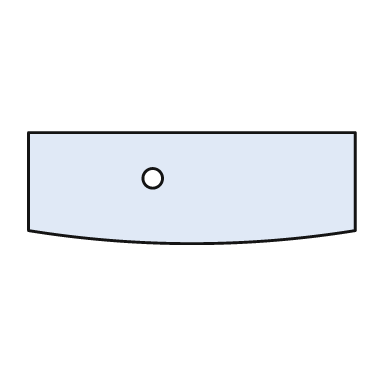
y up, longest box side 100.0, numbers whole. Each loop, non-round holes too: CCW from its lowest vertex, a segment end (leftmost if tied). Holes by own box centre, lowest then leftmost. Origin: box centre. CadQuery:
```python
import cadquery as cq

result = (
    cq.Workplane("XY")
    .moveTo(-50.0, -13.0)
    .threePointArc((0.0, -17.0), (50.0, -13.0))
    .lineTo(50.0, 17.0)
    .lineTo(-50.0, 17.0)
    .close()
    .moveTo(-12.0, 3.0)
    .circle(3.0)
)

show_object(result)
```